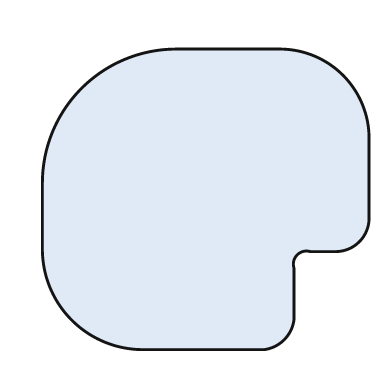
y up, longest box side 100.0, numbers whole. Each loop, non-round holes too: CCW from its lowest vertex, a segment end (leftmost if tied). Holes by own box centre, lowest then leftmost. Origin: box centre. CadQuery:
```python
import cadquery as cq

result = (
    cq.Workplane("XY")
    .moveTo(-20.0, -46.0)
    .lineTo(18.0, -46.0)
    .threePointArc((24.0, -43.0), (27.0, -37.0))
    .lineTo(27.0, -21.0)
    .threePointArc((28.0, -17.0), (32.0, -16.0))
    .lineTo(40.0, -16.0)
    .threePointArc((47.0, -13.0), (50.0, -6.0))
    .lineTo(50.0, 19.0)
    .threePointArc((42.0, 38.0), (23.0, 46.0))
    .lineTo(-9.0, 46.0)
    .threePointArc((-38.0, 34.0), (-50.0, 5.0))
    .lineTo(-50.0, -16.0)
    .threePointArc((-41.0, -37.0), (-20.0, -46.0))
    .close()
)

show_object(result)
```